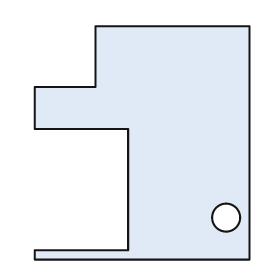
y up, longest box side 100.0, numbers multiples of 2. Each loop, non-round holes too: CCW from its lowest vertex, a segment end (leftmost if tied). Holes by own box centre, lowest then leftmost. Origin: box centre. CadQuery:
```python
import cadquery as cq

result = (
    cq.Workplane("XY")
    .moveTo(-46.0, -50.0)
    .lineTo(46.0, -50.0)
    .lineTo(46.0, 50.0)
    .lineTo(-20.0, 50.0)
    .lineTo(-20.0, 24.0)
    .lineTo(-46.0, 24.0)
    .lineTo(-46.0, 6.0)
    .lineTo(-6.0, 6.0)
    .lineTo(-6.0, -46.0)
    .lineTo(-46.0, -46.0)
    .close()
    .moveTo(36.0, -32.0)
    .circle(6.0)
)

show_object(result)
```